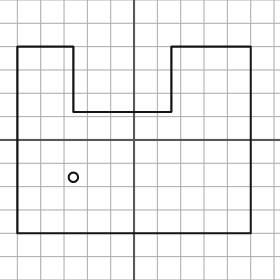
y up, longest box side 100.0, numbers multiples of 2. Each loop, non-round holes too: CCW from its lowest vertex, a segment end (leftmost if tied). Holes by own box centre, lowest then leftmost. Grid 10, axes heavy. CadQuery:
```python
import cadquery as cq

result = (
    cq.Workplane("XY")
    .moveTo(-50.0, -40.0)
    .lineTo(50.0, -40.0)
    .lineTo(50.0, 40.0)
    .lineTo(16.0, 40.0)
    .lineTo(16.0, 12.0)
    .lineTo(-26.0, 12.0)
    .lineTo(-26.0, 40.0)
    .lineTo(-50.0, 40.0)
    .close()
    .moveTo(-26.0, -16.0)
    .circle(2.0)
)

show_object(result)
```